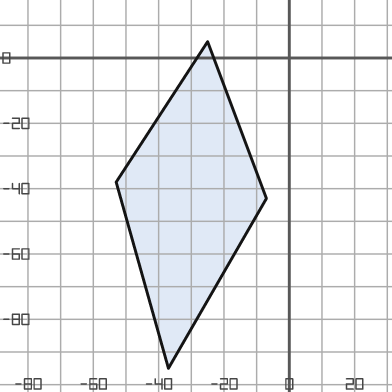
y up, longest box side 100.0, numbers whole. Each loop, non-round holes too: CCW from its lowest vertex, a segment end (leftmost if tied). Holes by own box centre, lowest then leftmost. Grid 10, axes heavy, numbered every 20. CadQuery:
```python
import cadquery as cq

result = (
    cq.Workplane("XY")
    .moveTo(-37.0, -95.0)
    .lineTo(-7.0, -43.0)
    .lineTo(-25.0, 5.0)
    .lineTo(-53.0, -38.0)
    .close()
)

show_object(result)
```